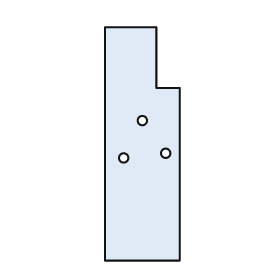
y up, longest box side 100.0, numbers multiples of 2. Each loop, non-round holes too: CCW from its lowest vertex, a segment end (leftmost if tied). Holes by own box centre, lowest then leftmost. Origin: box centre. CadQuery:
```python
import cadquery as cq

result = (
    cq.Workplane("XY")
    .moveTo(-16.0, -50.0)
    .lineTo(16.0, -50.0)
    .lineTo(16.0, 24.0)
    .lineTo(6.0, 24.0)
    .lineTo(6.0, 50.0)
    .lineTo(-16.0, 50.0)
    .close()
    .moveTo(-8.0, -6.0)
    .circle(2.0)
    .moveTo(10.0, -4.0)
    .circle(2.0)
    .moveTo(0.0, 10.0)
    .circle(2.0)
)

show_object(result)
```